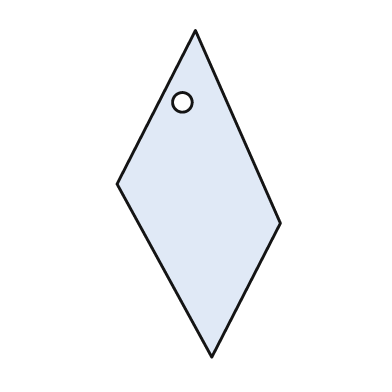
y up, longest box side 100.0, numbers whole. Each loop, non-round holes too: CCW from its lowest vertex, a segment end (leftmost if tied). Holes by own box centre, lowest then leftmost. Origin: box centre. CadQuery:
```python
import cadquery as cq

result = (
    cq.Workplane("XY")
    .moveTo(4.0, -50.0)
    .lineTo(25.0, -9.0)
    .lineTo(-1.0, 50.0)
    .lineTo(-25.0, 3.0)
    .close()
    .moveTo(-5.0, 28.0)
    .circle(3.0)
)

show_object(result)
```